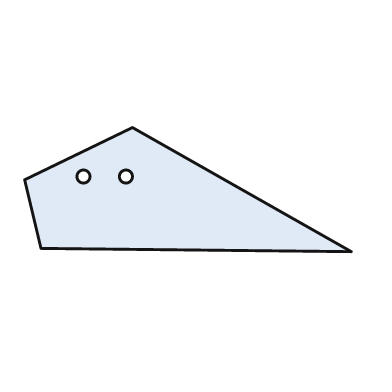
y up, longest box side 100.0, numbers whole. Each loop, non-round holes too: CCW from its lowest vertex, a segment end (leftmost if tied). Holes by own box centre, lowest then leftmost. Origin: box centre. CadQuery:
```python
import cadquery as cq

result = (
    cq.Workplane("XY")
    .moveTo(50.0, -19.0)
    .lineTo(-17.0, 19.0)
    .lineTo(-50.0, 3.0)
    .lineTo(-45.0, -18.0)
    .close()
    .moveTo(-32.0, 4.0)
    .circle(2.0)
    .moveTo(-19.0, 4.0)
    .circle(2.0)
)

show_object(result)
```